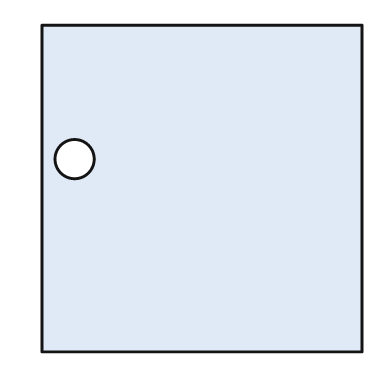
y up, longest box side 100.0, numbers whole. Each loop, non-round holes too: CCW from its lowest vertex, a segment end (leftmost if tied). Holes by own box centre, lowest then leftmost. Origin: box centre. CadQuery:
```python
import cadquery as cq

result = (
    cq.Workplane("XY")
    .moveTo(-49.0, -50.0)
    .lineTo(49.0, -50.0)
    .lineTo(49.0, 50.0)
    .lineTo(-49.0, 50.0)
    .close()
    .moveTo(-39.0, 9.0)
    .circle(6.0)
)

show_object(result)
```